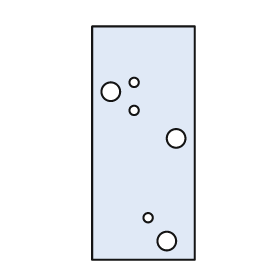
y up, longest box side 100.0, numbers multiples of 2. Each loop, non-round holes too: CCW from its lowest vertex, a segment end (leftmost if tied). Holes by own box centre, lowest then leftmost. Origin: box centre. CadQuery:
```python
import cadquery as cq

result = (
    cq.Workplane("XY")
    .moveTo(-22.0, -50.0)
    .lineTo(22.0, -50.0)
    .lineTo(22.0, 50.0)
    .lineTo(-22.0, 50.0)
    .close()
    .moveTo(10.0, -42.0)
    .circle(4.0)
    .moveTo(2.0, -32.0)
    .circle(2.0)
    .moveTo(14.0, 2.0)
    .circle(4.0)
    .moveTo(-4.0, 14.0)
    .circle(2.0)
    .moveTo(-14.0, 22.0)
    .circle(4.0)
    .moveTo(-4.0, 26.0)
    .circle(2.0)
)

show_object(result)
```